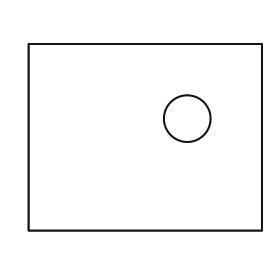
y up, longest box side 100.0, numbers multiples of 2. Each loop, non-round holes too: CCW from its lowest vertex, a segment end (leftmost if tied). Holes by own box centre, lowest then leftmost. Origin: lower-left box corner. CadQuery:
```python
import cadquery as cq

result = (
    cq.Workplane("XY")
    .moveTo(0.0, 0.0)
    .lineTo(100.0, 0.0)
    .lineTo(100.0, 80.0)
    .lineTo(0.0, 80.0)
    .close()
    .moveTo(68.0, 48.0)
    .circle(10.0)
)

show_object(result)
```